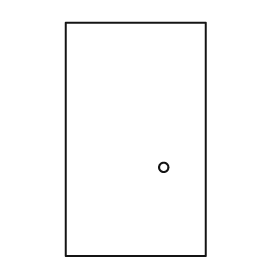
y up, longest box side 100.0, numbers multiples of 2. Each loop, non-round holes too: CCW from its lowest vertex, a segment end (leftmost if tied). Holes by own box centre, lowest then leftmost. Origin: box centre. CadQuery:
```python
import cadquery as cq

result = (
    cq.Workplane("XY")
    .moveTo(-30.0, -50.0)
    .lineTo(30.0, -50.0)
    .lineTo(30.0, 50.0)
    .lineTo(-30.0, 50.0)
    .close()
    .moveTo(12.0, -12.0)
    .circle(2.0)
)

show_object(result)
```